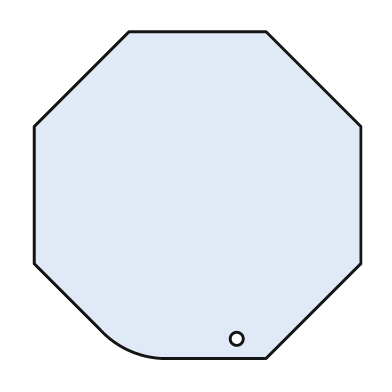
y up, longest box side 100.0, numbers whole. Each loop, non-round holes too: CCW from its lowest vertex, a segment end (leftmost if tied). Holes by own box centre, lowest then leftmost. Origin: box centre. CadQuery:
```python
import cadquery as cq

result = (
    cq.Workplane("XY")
    .moveTo(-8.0, -50.0)
    .lineTo(21.0, -50.0)
    .lineTo(50.0, -21.0)
    .lineTo(50.0, 21.0)
    .lineTo(21.0, 50.0)
    .lineTo(-21.0, 50.0)
    .lineTo(-50.0, 21.0)
    .lineTo(-50.0, -21.0)
    .lineTo(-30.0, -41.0)
    .threePointArc((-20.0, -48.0), (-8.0, -50.0))
    .close()
    .moveTo(12.0, -44.0)
    .circle(2.0)
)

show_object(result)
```